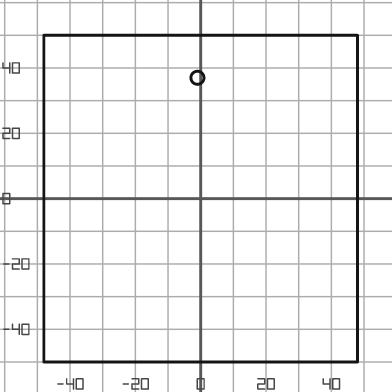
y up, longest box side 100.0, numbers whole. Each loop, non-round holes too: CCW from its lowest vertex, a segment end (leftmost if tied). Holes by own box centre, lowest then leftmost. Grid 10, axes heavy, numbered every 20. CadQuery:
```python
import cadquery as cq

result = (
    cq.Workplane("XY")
    .moveTo(-48.0, -50.0)
    .lineTo(48.0, -50.0)
    .lineTo(48.0, 50.0)
    .lineTo(-48.0, 50.0)
    .close()
    .moveTo(-1.0, 37.0)
    .circle(2.0)
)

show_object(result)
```